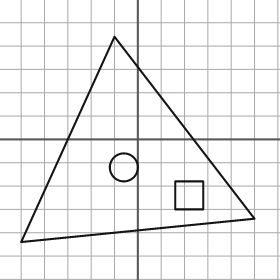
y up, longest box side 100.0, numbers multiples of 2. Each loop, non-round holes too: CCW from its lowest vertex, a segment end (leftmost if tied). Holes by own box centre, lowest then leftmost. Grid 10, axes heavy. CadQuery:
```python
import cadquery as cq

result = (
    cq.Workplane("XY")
    .moveTo(-50.0, -44.0)
    .lineTo(50.0, -34.0)
    .lineTo(-10.0, 44.0)
    .close()
    .moveTo(16.0, -30.0)
    .lineTo(28.0, -30.0)
    .lineTo(28.0, -18.0)
    .lineTo(16.0, -18.0)
    .close()
    .moveTo(-6.0, -12.0)
    .circle(6.0)
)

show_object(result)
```